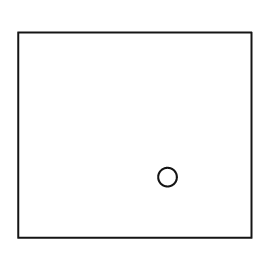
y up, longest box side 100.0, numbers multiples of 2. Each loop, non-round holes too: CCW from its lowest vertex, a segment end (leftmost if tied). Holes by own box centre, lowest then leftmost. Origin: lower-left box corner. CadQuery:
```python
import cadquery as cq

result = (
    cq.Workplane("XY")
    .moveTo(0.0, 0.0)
    .lineTo(100.0, 0.0)
    .lineTo(100.0, 88.0)
    .lineTo(0.0, 88.0)
    .close()
    .moveTo(64.0, 26.0)
    .circle(4.0)
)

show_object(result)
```